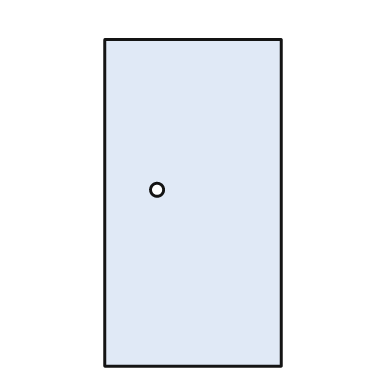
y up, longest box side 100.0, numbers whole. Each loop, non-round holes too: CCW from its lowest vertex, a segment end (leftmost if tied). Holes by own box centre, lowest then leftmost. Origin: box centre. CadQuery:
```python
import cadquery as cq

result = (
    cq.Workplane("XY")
    .moveTo(-27.0, -50.0)
    .lineTo(27.0, -50.0)
    .lineTo(27.0, 50.0)
    .lineTo(-27.0, 50.0)
    .close()
    .moveTo(-11.0, 4.0)
    .circle(2.0)
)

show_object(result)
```